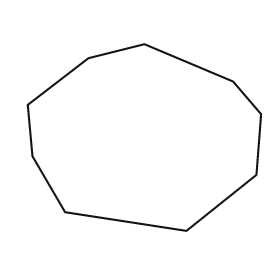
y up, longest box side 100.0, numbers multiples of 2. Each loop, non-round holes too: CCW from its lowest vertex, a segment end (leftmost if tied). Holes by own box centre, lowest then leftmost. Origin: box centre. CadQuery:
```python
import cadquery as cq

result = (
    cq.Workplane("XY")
    .moveTo(18.0, -40.0)
    .lineTo(48.0, -16.0)
    .lineTo(50.0, 10.0)
    .lineTo(38.0, 24.0)
    .lineTo(0.0, 40.0)
    .lineTo(-24.0, 34.0)
    .lineTo(-50.0, 14.0)
    .lineTo(-48.0, -8.0)
    .lineTo(-34.0, -32.0)
    .close()
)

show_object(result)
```